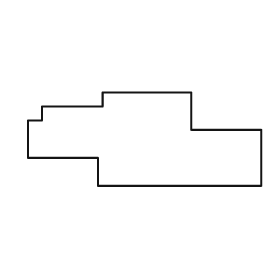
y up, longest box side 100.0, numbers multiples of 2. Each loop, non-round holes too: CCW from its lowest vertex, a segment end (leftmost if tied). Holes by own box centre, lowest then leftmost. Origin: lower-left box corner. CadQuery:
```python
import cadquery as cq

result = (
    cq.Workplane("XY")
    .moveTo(30.0, 0.0)
    .lineTo(100.0, 0.0)
    .lineTo(100.0, 24.0)
    .lineTo(70.0, 24.0)
    .lineTo(70.0, 40.0)
    .lineTo(32.0, 40.0)
    .lineTo(32.0, 34.0)
    .lineTo(6.0, 34.0)
    .lineTo(6.0, 28.0)
    .lineTo(0.0, 28.0)
    .lineTo(0.0, 12.0)
    .lineTo(30.0, 12.0)
    .close()
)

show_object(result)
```